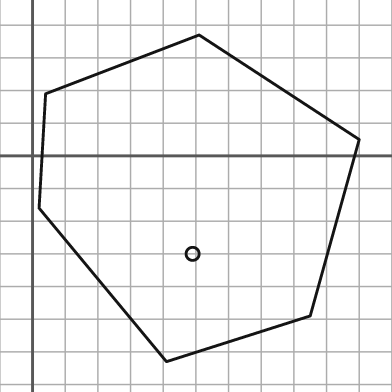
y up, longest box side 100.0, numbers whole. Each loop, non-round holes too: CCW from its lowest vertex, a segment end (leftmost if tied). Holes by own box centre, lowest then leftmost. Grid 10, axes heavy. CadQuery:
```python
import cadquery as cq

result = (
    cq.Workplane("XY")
    .moveTo(41.0, -63.0)
    .lineTo(85.0, -49.0)
    .lineTo(100.0, 5.0)
    .lineTo(51.0, 37.0)
    .lineTo(4.0, 19.0)
    .lineTo(2.0, -16.0)
    .close()
    .moveTo(49.0, -30.0)
    .circle(2.0)
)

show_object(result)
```